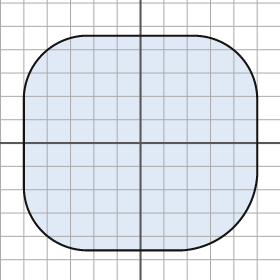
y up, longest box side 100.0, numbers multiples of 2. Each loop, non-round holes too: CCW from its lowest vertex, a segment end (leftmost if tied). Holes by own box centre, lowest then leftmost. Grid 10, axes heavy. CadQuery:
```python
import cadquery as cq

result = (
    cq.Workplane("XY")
    .moveTo(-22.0, -46.0)
    .lineTo(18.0, -46.0)
    .threePointArc((40.0, -36.0), (50.0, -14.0))
    .lineTo(50.0, 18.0)
    .threePointArc((42.0, 38.0), (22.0, 46.0))
    .lineTo(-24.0, 46.0)
    .threePointArc((-42.0, 38.0), (-50.0, 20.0))
    .lineTo(-50.0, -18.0)
    .threePointArc((-42.0, -38.0), (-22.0, -46.0))
    .close()
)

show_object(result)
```